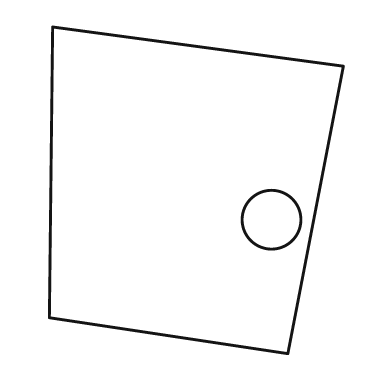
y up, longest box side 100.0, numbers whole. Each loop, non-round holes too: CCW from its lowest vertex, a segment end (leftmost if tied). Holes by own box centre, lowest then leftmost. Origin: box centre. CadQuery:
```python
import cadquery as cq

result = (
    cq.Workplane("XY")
    .moveTo(28.0, -50.0)
    .lineTo(45.0, 38.0)
    .lineTo(-44.0, 50.0)
    .lineTo(-45.0, -39.0)
    .close()
    .moveTo(23.0, -9.0)
    .circle(9.0)
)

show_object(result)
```